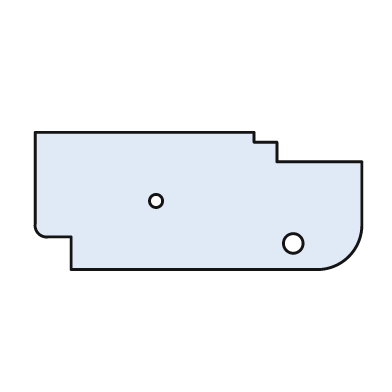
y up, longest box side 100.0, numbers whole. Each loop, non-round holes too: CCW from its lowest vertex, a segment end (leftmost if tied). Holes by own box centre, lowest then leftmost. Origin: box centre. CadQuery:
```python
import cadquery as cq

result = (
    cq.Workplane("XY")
    .moveTo(-39.0, -21.0)
    .lineTo(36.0, -21.0)
    .threePointArc((46.0, -17.0), (50.0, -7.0))
    .lineTo(50.0, 12.0)
    .lineTo(24.0, 12.0)
    .lineTo(24.0, 18.0)
    .lineTo(17.0, 18.0)
    .lineTo(17.0, 21.0)
    .lineTo(-50.0, 21.0)
    .lineTo(-50.0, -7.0)
    .threePointArc((-49.0, -10.0), (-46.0, -11.0))
    .lineTo(-39.0, -11.0)
    .close()
    .moveTo(29.0, -13.0)
    .circle(3.0)
    .moveTo(-13.0, 0.0)
    .circle(2.0)
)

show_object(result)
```